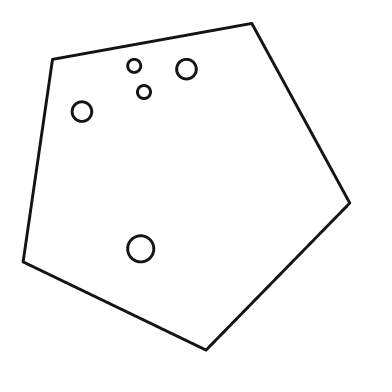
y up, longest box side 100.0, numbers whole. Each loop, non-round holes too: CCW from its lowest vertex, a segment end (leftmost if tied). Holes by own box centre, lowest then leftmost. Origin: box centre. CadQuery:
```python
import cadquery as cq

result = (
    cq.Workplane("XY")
    .moveTo(6.0, -50.0)
    .lineTo(50.0, -5.0)
    .lineTo(20.0, 50.0)
    .lineTo(-41.0, 39.0)
    .lineTo(-50.0, -23.0)
    .close()
    .moveTo(-14.0, -19.0)
    .circle(4.0)
    .moveTo(-32.0, 23.0)
    .circle(3.0)
    .moveTo(-13.0, 29.0)
    .circle(2.0)
    .moveTo(0.0, 36.0)
    .circle(3.0)
    .moveTo(-16.0, 37.0)
    .circle(2.0)
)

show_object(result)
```